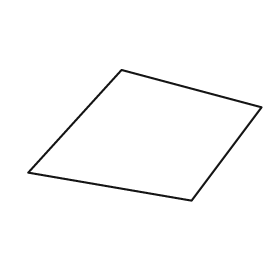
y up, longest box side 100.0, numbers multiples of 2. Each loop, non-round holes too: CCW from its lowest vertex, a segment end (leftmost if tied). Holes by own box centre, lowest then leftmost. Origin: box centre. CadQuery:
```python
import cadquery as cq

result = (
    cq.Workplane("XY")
    .moveTo(20.0, -28.0)
    .lineTo(50.0, 12.0)
    .lineTo(-10.0, 28.0)
    .lineTo(-50.0, -16.0)
    .close()
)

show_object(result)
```